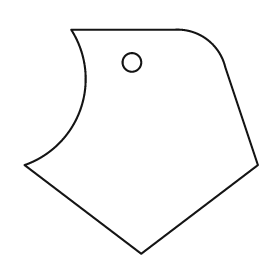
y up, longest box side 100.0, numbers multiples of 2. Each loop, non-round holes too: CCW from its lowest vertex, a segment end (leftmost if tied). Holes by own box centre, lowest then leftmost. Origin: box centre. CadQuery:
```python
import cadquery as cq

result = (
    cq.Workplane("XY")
    .moveTo(0.0, -48.0)
    .lineTo(50.0, -10.0)
    .lineTo(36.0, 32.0)
    .threePointArc((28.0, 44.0), (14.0, 48.0))
    .lineTo(-30.0, 48.0)
    .threePointArc((-26.0, 14.0), (-50.0, -10.0))
    .close()
    .moveTo(-4.0, 34.0)
    .circle(4.0)
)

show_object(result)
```